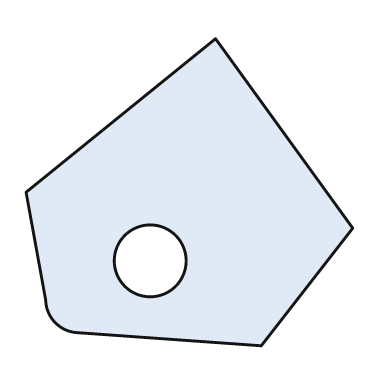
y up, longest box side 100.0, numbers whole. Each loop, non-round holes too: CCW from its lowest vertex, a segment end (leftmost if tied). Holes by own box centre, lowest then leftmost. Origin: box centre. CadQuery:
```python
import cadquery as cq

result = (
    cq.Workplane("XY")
    .moveTo(22.0, -47.0)
    .lineTo(50.0, -11.0)
    .lineTo(8.0, 47.0)
    .lineTo(-50.0, 0.0)
    .lineTo(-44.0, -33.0)
    .threePointArc((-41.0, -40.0), (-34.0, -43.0))
    .close()
    .moveTo(-12.0, -21.0)
    .circle(11.0)
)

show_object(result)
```